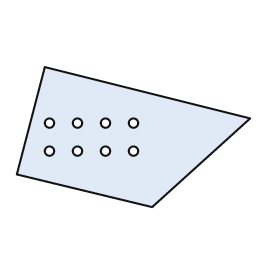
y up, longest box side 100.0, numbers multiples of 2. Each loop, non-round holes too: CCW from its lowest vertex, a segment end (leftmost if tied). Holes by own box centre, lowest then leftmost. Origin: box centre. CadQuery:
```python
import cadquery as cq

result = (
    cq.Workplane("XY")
    .moveTo(8.0, -30.0)
    .lineTo(50.0, 8.0)
    .lineTo(-38.0, 30.0)
    .lineTo(-50.0, -16.0)
    .close()
    .moveTo(-36.0, -6.0)
    .circle(2.0)
    .moveTo(-24.0, -6.0)
    .circle(2.0)
    .moveTo(-12.0, -6.0)
    .circle(2.0)
    .moveTo(0.0, -6.0)
    .circle(2.0)
    .moveTo(-36.0, 6.0)
    .circle(2.0)
    .moveTo(-24.0, 6.0)
    .circle(2.0)
    .moveTo(-12.0, 6.0)
    .circle(2.0)
    .moveTo(0.0, 6.0)
    .circle(2.0)
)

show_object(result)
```